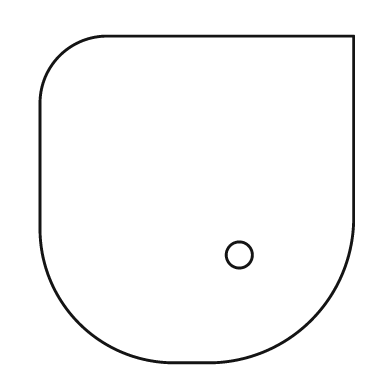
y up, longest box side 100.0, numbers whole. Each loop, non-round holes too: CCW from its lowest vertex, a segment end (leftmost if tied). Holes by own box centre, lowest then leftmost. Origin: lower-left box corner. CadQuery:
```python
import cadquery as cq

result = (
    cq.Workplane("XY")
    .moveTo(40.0, 0.0)
    .lineTo(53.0, 0.0)
    .threePointArc((83.0, 13.0), (96.0, 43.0))
    .lineTo(96.0, 100.0)
    .lineTo(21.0, 100.0)
    .threePointArc((6.0, 94.0), (0.0, 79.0))
    .lineTo(0.0, 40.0)
    .threePointArc((12.0, 12.0), (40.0, 0.0))
    .close()
    .moveTo(61.0, 33.0)
    .circle(4.0)
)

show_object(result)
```